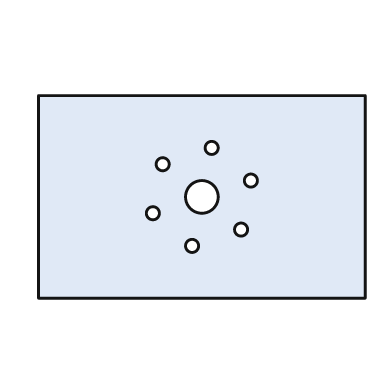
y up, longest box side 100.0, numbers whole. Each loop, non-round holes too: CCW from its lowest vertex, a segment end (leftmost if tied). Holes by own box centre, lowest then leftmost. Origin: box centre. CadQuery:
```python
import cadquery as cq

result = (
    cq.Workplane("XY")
    .moveTo(-50.0, -31.0)
    .lineTo(50.0, -31.0)
    .lineTo(50.0, 31.0)
    .lineTo(-50.0, 31.0)
    .close()
    .moveTo(-3.0, -15.0)
    .circle(2.0)
    .moveTo(12.0, -10.0)
    .circle(2.0)
    .moveTo(-15.0, -5.0)
    .circle(2.0)
    .moveTo(0.0, 0.0)
    .circle(5.0)
    .moveTo(15.0, 5.0)
    .circle(2.0)
    .moveTo(-12.0, 10.0)
    .circle(2.0)
    .moveTo(3.0, 15.0)
    .circle(2.0)
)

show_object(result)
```